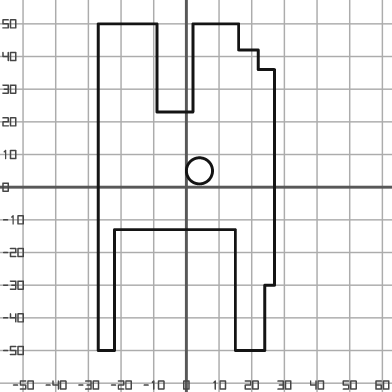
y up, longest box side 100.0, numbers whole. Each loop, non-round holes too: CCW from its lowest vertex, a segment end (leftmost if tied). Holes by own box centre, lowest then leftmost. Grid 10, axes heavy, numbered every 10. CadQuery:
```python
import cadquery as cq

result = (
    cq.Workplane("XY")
    .moveTo(-27.0, -50.0)
    .lineTo(-22.0, -50.0)
    .lineTo(-22.0, -13.0)
    .lineTo(15.0, -13.0)
    .lineTo(15.0, -50.0)
    .lineTo(24.0, -50.0)
    .lineTo(24.0, -30.0)
    .lineTo(27.0, -30.0)
    .lineTo(27.0, 36.0)
    .lineTo(22.0, 36.0)
    .lineTo(22.0, 42.0)
    .lineTo(16.0, 42.0)
    .lineTo(16.0, 50.0)
    .lineTo(2.0, 50.0)
    .lineTo(2.0, 23.0)
    .lineTo(-9.0, 23.0)
    .lineTo(-9.0, 50.0)
    .lineTo(-27.0, 50.0)
    .close()
    .moveTo(4.0, 5.0)
    .circle(4.0)
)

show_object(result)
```